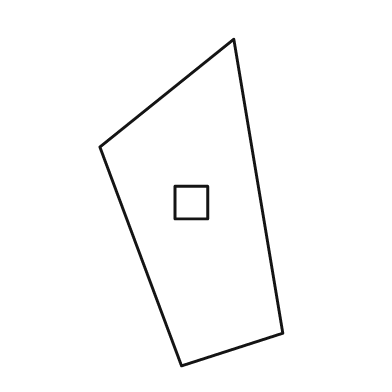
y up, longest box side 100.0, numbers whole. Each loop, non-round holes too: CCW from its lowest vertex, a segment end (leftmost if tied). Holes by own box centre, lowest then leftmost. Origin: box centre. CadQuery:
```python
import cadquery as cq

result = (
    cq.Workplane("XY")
    .moveTo(-3.0, -50.0)
    .lineTo(28.0, -40.0)
    .lineTo(13.0, 50.0)
    .lineTo(-28.0, 17.0)
    .close()
    .moveTo(-5.0, -5.0)
    .lineTo(5.0, -5.0)
    .lineTo(5.0, 5.0)
    .lineTo(-5.0, 5.0)
    .close()
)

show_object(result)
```